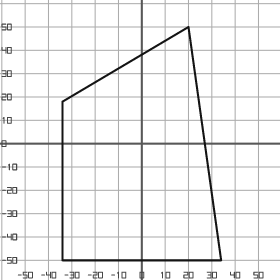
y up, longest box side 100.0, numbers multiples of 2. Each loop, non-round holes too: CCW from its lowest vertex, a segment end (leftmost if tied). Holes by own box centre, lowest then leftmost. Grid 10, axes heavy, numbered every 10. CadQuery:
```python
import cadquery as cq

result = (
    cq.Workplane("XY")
    .moveTo(-34.0, -50.0)
    .lineTo(34.0, -50.0)
    .lineTo(20.0, 50.0)
    .lineTo(-34.0, 18.0)
    .close()
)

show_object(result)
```